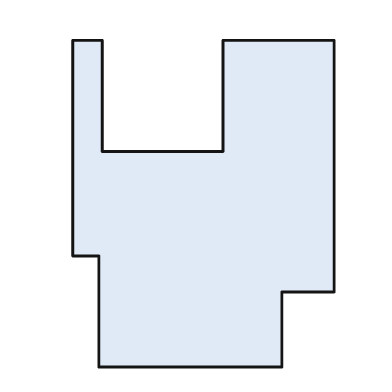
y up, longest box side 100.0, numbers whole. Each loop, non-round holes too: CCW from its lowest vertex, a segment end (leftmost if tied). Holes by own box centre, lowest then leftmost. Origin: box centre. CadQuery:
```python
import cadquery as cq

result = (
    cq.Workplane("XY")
    .moveTo(-32.0, -50.0)
    .lineTo(24.0, -50.0)
    .lineTo(24.0, -27.0)
    .lineTo(40.0, -27.0)
    .lineTo(40.0, 50.0)
    .lineTo(6.0, 50.0)
    .lineTo(6.0, 16.0)
    .lineTo(-31.0, 16.0)
    .lineTo(-31.0, 50.0)
    .lineTo(-40.0, 50.0)
    .lineTo(-40.0, -16.0)
    .lineTo(-32.0, -16.0)
    .close()
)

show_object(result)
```